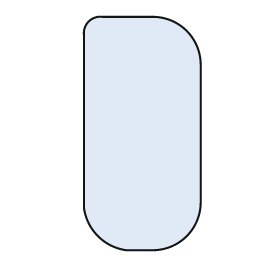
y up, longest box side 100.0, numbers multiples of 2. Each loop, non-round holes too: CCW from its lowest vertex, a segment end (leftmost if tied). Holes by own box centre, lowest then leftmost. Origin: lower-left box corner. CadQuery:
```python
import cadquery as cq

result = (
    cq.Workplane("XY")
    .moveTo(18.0, 0.0)
    .lineTo(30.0, 0.0)
    .threePointArc((44.0, 6.0), (50.0, 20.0))
    .lineTo(50.0, 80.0)
    .threePointArc((44.0, 94.0), (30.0, 100.0))
    .lineTo(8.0, 100.0)
    .threePointArc((2.0, 98.0), (0.0, 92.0))
    .lineTo(0.0, 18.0)
    .threePointArc((6.0, 6.0), (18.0, 0.0))
    .close()
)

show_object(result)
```